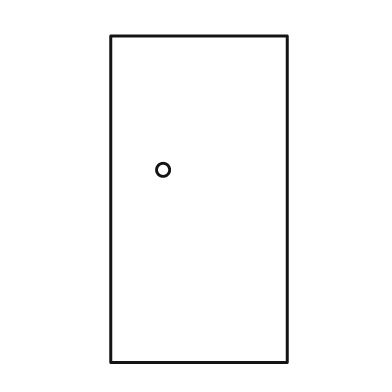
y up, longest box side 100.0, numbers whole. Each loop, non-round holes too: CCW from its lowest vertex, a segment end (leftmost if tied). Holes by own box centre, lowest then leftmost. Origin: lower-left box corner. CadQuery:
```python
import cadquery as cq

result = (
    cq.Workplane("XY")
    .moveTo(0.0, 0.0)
    .lineTo(54.0, 0.0)
    .lineTo(54.0, 100.0)
    .lineTo(0.0, 100.0)
    .close()
    .moveTo(16.0, 59.0)
    .circle(2.0)
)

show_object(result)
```